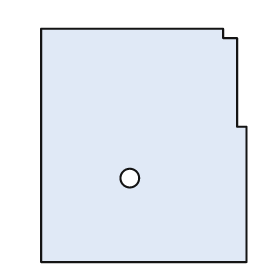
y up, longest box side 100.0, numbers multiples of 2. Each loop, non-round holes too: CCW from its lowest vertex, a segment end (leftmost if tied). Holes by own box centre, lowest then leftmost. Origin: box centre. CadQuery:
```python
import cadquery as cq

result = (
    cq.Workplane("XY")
    .moveTo(-44.0, -50.0)
    .lineTo(44.0, -50.0)
    .lineTo(44.0, 8.0)
    .lineTo(40.0, 8.0)
    .lineTo(40.0, 46.0)
    .lineTo(34.0, 46.0)
    .lineTo(34.0, 50.0)
    .lineTo(-44.0, 50.0)
    .close()
    .moveTo(-6.0, -14.0)
    .circle(4.0)
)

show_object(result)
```